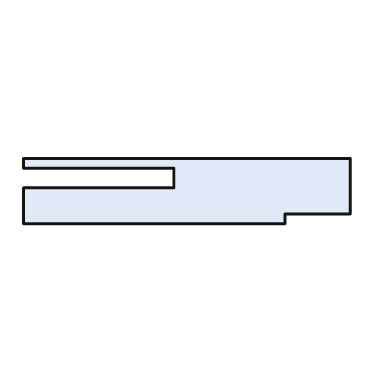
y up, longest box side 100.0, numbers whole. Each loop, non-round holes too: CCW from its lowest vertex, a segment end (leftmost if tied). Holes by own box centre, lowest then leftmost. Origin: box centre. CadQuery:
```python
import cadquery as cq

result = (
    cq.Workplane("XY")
    .moveTo(-50.0, -10.0)
    .lineTo(30.0, -10.0)
    .lineTo(30.0, -7.0)
    .lineTo(50.0, -7.0)
    .lineTo(50.0, 10.0)
    .lineTo(-50.0, 10.0)
    .lineTo(-50.0, 7.0)
    .lineTo(-4.0, 7.0)
    .lineTo(-4.0, 1.0)
    .lineTo(-50.0, 1.0)
    .close()
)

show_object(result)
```